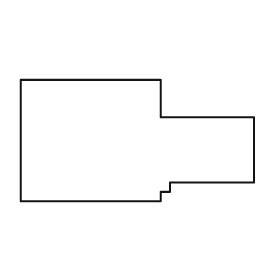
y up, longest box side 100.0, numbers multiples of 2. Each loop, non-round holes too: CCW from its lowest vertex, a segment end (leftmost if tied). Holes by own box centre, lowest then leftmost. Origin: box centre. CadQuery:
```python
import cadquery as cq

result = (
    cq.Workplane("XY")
    .moveTo(-50.0, -26.0)
    .lineTo(10.0, -26.0)
    .lineTo(10.0, -22.0)
    .lineTo(14.0, -22.0)
    .lineTo(14.0, -18.0)
    .lineTo(50.0, -18.0)
    .lineTo(50.0, 10.0)
    .lineTo(10.0, 10.0)
    .lineTo(10.0, 26.0)
    .lineTo(-50.0, 26.0)
    .close()
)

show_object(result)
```